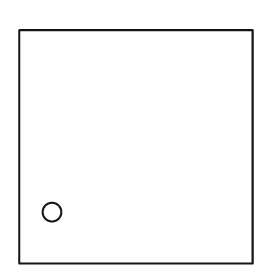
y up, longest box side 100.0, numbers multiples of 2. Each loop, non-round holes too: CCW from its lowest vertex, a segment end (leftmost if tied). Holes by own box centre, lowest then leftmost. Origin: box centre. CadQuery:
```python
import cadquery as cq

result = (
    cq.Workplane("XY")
    .moveTo(-50.0, -50.0)
    .lineTo(50.0, -50.0)
    .lineTo(50.0, 50.0)
    .lineTo(-50.0, 50.0)
    .close()
    .moveTo(-36.0, -28.0)
    .circle(4.0)
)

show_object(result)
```